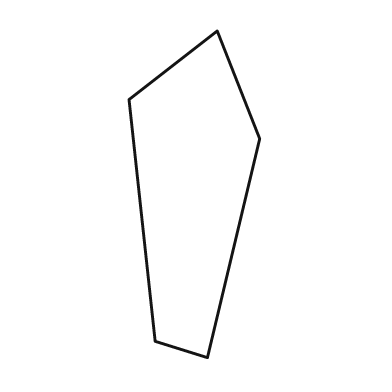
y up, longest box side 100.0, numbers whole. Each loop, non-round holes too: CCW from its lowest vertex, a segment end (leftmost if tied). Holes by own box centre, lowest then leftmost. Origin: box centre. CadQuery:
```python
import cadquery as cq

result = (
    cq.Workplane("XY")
    .moveTo(4.0, -50.0)
    .lineTo(20.0, 17.0)
    .lineTo(7.0, 50.0)
    .lineTo(-20.0, 29.0)
    .lineTo(-12.0, -45.0)
    .close()
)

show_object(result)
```